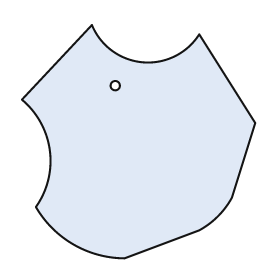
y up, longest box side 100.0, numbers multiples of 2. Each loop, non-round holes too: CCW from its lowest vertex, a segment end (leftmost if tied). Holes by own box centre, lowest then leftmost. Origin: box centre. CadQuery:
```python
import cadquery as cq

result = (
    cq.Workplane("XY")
    .moveTo(-6.0, -50.0)
    .lineTo(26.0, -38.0)
    .threePointArc((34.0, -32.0), (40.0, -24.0))
    .lineTo(50.0, 8.0)
    .lineTo(26.0, 46.0)
    .threePointArc((2.0, 34.0), (-20.0, 50.0))
    .lineTo(-50.0, 18.0)
    .threePointArc((-38.0, -4.0), (-44.0, -28.0))
    .threePointArc((-28.0, -44.0), (-6.0, -50.0))
    .close()
    .moveTo(-10.0, 24.0)
    .circle(2.0)
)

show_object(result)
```